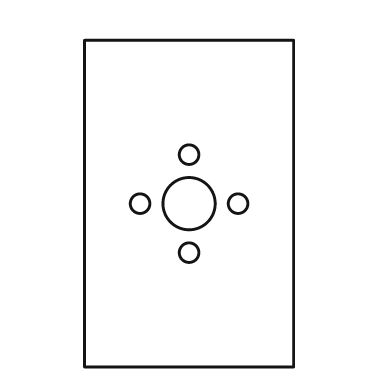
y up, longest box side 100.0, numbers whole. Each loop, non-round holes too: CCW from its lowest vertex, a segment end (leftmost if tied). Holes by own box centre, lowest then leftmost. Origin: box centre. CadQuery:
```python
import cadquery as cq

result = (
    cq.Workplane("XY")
    .moveTo(-32.0, -50.0)
    .lineTo(32.0, -50.0)
    .lineTo(32.0, 50.0)
    .lineTo(-32.0, 50.0)
    .close()
    .moveTo(0.0, -15.0)
    .circle(3.0)
    .moveTo(-15.0, 0.0)
    .circle(3.0)
    .moveTo(0.0, 0.0)
    .circle(8.0)
    .moveTo(15.0, 0.0)
    .circle(3.0)
    .moveTo(0.0, 15.0)
    .circle(3.0)
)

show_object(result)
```